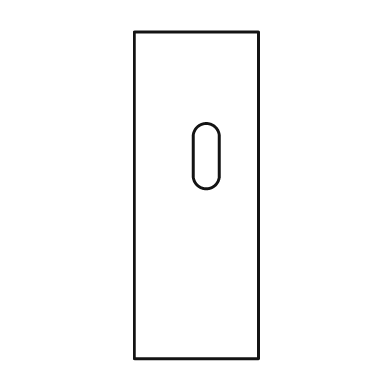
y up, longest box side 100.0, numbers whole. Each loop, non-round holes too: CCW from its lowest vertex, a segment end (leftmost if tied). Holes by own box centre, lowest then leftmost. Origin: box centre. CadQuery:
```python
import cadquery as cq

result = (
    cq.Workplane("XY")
    .moveTo(-19.0, -50.0)
    .lineTo(19.0, -50.0)
    .lineTo(19.0, 50.0)
    .lineTo(-19.0, 50.0)
    .close()
    .moveTo(-1.0, 6.0)
    .threePointArc((3.0, 2.0), (7.0, 6.0))
    .lineTo(7.0, 18.0)
    .threePointArc((3.0, 22.0), (-1.0, 18.0))
    .close()
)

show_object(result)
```